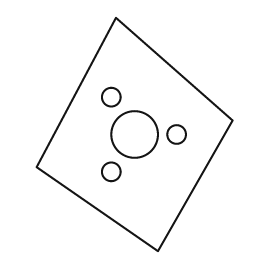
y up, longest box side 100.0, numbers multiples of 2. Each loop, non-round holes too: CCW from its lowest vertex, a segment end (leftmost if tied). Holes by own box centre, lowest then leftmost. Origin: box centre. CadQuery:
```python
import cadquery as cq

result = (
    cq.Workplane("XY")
    .moveTo(10.0, -50.0)
    .lineTo(42.0, 6.0)
    .lineTo(-8.0, 50.0)
    .lineTo(-42.0, -14.0)
    .close()
    .moveTo(-10.0, -16.0)
    .circle(4.0)
    .moveTo(0.0, 0.0)
    .circle(10.0)
    .moveTo(18.0, 0.0)
    .circle(4.0)
    .moveTo(-10.0, 16.0)
    .circle(4.0)
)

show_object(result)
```